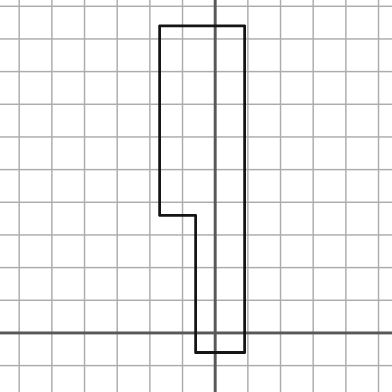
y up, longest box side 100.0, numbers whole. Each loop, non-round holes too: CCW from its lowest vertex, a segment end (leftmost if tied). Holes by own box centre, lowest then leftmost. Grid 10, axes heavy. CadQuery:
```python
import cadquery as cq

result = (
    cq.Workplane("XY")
    .moveTo(-6.0, -6.0)
    .lineTo(9.0, -6.0)
    .lineTo(9.0, 94.0)
    .lineTo(-17.0, 94.0)
    .lineTo(-17.0, 36.0)
    .lineTo(-6.0, 36.0)
    .close()
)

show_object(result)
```